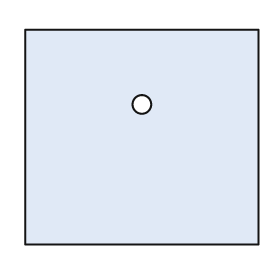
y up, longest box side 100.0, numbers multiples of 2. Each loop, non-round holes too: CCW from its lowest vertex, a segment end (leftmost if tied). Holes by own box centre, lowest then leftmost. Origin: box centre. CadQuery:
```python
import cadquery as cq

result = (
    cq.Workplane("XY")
    .moveTo(-50.0, -46.0)
    .lineTo(50.0, -46.0)
    .lineTo(50.0, 46.0)
    .lineTo(-50.0, 46.0)
    .close()
    .moveTo(0.0, 14.0)
    .circle(4.0)
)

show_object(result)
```